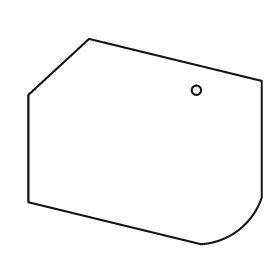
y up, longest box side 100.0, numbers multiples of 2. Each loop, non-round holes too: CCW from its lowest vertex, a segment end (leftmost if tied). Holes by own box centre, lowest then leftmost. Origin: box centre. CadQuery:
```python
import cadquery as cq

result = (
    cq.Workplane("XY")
    .moveTo(24.0, -44.0)
    .threePointArc((40.0, -38.0), (50.0, -24.0))
    .lineTo(50.0, 26.0)
    .lineTo(-24.0, 44.0)
    .lineTo(-50.0, 20.0)
    .lineTo(-50.0, -26.0)
    .close()
    .moveTo(22.0, 22.0)
    .circle(2.0)
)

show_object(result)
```